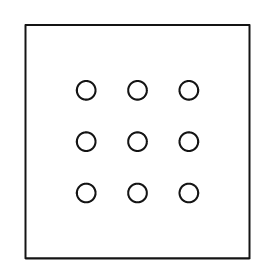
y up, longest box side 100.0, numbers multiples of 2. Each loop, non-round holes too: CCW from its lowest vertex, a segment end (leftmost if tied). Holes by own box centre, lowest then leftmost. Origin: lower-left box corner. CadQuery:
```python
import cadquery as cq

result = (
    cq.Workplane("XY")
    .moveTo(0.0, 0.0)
    .lineTo(96.0, 0.0)
    .lineTo(96.0, 100.0)
    .lineTo(0.0, 100.0)
    .close()
    .moveTo(26.0, 28.0)
    .circle(4.0)
    .moveTo(48.0, 28.0)
    .circle(4.0)
    .moveTo(70.0, 28.0)
    .circle(4.0)
    .moveTo(26.0, 50.0)
    .circle(4.0)
    .moveTo(48.0, 50.0)
    .circle(4.0)
    .moveTo(70.0, 50.0)
    .circle(4.0)
    .moveTo(26.0, 72.0)
    .circle(4.0)
    .moveTo(48.0, 72.0)
    .circle(4.0)
    .moveTo(70.0, 72.0)
    .circle(4.0)
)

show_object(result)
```